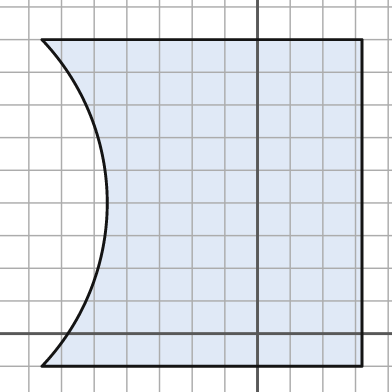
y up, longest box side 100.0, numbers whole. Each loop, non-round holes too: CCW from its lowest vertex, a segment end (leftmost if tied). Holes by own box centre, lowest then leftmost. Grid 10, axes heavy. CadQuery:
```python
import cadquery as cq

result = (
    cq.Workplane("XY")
    .moveTo(-66.0, -10.0)
    .lineTo(32.0, -10.0)
    .lineTo(32.0, 90.0)
    .lineTo(-66.0, 90.0)
    .threePointArc((-46.0, 40.0), (-66.0, -10.0))
    .close()
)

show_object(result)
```